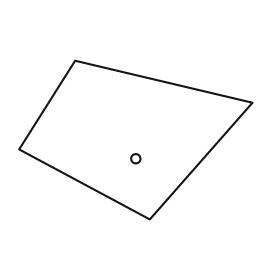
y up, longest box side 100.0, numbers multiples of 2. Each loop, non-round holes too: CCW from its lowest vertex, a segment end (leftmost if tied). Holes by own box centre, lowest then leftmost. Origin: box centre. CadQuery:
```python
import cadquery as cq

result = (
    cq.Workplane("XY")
    .moveTo(6.0, -34.0)
    .lineTo(50.0, 16.0)
    .lineTo(-26.0, 34.0)
    .lineTo(-50.0, -4.0)
    .close()
    .moveTo(0.0, -8.0)
    .circle(2.0)
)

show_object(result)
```